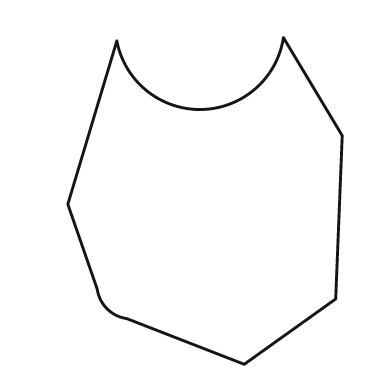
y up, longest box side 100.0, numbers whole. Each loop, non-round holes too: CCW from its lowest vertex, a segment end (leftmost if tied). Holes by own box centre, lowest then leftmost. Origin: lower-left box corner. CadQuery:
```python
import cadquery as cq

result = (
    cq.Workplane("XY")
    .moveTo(54.0, 0.0)
    .lineTo(82.0, 20.0)
    .lineTo(84.0, 70.0)
    .lineTo(66.0, 100.0)
    .threePointArc((41.0, 78.0), (15.0, 99.0))
    .lineTo(0.0, 49.0)
    .lineTo(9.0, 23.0)
    .threePointArc((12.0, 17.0), (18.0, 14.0))
    .close()
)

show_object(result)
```